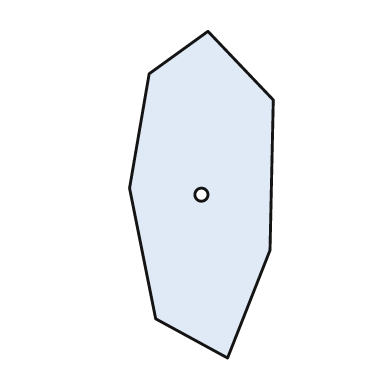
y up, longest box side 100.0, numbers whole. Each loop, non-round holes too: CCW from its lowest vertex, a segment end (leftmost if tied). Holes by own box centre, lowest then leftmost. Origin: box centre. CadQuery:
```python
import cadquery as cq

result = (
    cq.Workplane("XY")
    .moveTo(8.0, -50.0)
    .lineTo(21.0, -17.0)
    .lineTo(22.0, 29.0)
    .lineTo(2.0, 50.0)
    .lineTo(-16.0, 37.0)
    .lineTo(-22.0, 2.0)
    .lineTo(-14.0, -38.0)
    .close()
    .moveTo(0.0, 0.0)
    .circle(2.0)
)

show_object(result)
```